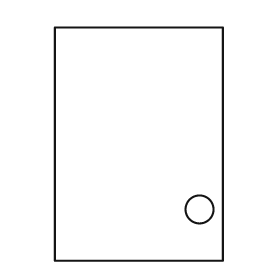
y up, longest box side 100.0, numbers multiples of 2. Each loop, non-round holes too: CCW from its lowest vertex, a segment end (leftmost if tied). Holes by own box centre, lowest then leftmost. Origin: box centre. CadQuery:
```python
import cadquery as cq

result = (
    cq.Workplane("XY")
    .moveTo(-36.0, -50.0)
    .lineTo(36.0, -50.0)
    .lineTo(36.0, 50.0)
    .lineTo(-36.0, 50.0)
    .close()
    .moveTo(26.0, -28.0)
    .circle(6.0)
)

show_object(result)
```